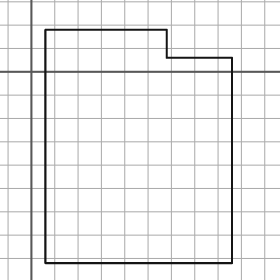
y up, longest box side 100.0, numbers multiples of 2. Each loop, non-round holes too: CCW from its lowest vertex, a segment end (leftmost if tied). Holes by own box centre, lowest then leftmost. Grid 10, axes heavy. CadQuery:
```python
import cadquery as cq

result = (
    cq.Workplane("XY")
    .moveTo(6.0, -82.0)
    .lineTo(86.0, -82.0)
    .lineTo(86.0, 6.0)
    .lineTo(58.0, 6.0)
    .lineTo(58.0, 18.0)
    .lineTo(6.0, 18.0)
    .close()
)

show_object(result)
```